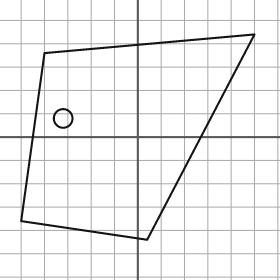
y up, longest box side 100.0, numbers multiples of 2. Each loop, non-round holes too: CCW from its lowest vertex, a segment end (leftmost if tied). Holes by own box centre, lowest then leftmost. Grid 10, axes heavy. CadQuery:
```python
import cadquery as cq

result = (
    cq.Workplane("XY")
    .moveTo(4.0, -44.0)
    .lineTo(50.0, 44.0)
    .lineTo(-40.0, 36.0)
    .lineTo(-50.0, -36.0)
    .close()
    .moveTo(-32.0, 8.0)
    .circle(4.0)
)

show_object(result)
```